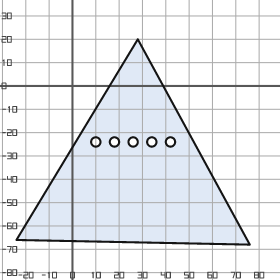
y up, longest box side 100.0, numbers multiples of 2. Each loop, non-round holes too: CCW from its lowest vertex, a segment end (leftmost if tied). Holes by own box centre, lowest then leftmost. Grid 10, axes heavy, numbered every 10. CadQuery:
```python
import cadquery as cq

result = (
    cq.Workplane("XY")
    .moveTo(76.0, -68.0)
    .lineTo(28.0, 20.0)
    .lineTo(-24.0, -66.0)
    .close()
    .moveTo(10.0, -24.0)
    .circle(2.0)
    .moveTo(18.0, -24.0)
    .circle(2.0)
    .moveTo(26.0, -24.0)
    .circle(2.0)
    .moveTo(34.0, -24.0)
    .circle(2.0)
    .moveTo(42.0, -24.0)
    .circle(2.0)
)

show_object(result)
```